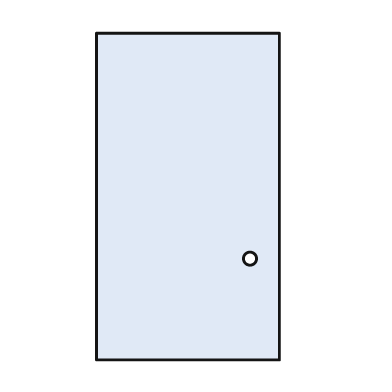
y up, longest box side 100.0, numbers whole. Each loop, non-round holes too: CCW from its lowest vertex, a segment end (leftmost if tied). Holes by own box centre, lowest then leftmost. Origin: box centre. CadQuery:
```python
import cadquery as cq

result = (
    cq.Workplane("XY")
    .moveTo(-28.0, -50.0)
    .lineTo(28.0, -50.0)
    .lineTo(28.0, 50.0)
    .lineTo(-28.0, 50.0)
    .close()
    .moveTo(19.0, -19.0)
    .circle(2.0)
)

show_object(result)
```